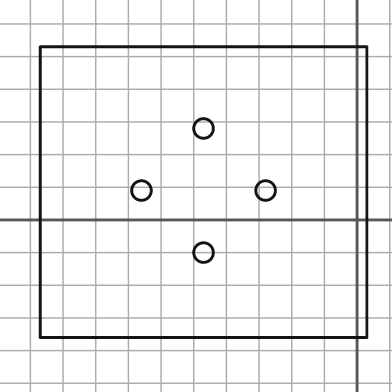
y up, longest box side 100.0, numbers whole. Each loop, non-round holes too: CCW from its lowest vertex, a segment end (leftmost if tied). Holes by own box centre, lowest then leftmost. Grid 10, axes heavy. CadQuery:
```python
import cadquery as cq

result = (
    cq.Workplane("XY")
    .moveTo(-97.0, -36.0)
    .lineTo(3.0, -36.0)
    .lineTo(3.0, 53.0)
    .lineTo(-97.0, 53.0)
    .close()
    .moveTo(-47.0, -10.0)
    .circle(3.0)
    .moveTo(-66.0, 9.0)
    .circle(3.0)
    .moveTo(-28.0, 9.0)
    .circle(3.0)
    .moveTo(-47.0, 28.0)
    .circle(3.0)
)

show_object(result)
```